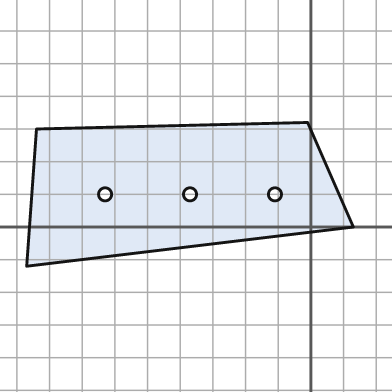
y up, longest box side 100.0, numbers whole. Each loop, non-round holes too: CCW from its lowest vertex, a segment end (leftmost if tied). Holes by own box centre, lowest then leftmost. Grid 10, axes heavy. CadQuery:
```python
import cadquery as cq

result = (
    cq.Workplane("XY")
    .moveTo(-87.0, -12.0)
    .lineTo(13.0, 0.0)
    .lineTo(-1.0, 32.0)
    .lineTo(-84.0, 30.0)
    .close()
    .moveTo(-63.0, 10.0)
    .circle(2.0)
    .moveTo(-37.0, 10.0)
    .circle(2.0)
    .moveTo(-11.0, 10.0)
    .circle(2.0)
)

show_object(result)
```